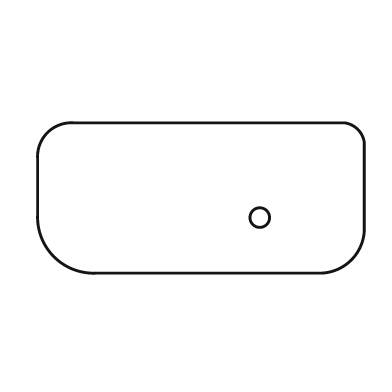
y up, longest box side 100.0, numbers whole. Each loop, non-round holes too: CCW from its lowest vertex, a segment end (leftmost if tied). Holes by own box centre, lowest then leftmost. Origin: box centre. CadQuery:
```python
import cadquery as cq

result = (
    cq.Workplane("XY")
    .moveTo(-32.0, -23.0)
    .lineTo(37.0, -23.0)
    .threePointArc((46.0, -19.0), (50.0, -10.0))
    .lineTo(50.0, 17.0)
    .threePointArc((48.0, 21.0), (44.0, 23.0))
    .lineTo(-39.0, 23.0)
    .threePointArc((-47.0, 20.0), (-50.0, 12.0))
    .lineTo(-50.0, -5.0)
    .threePointArc((-45.0, -18.0), (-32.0, -23.0))
    .close()
    .moveTo(18.0, -6.0)
    .circle(3.0)
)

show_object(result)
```